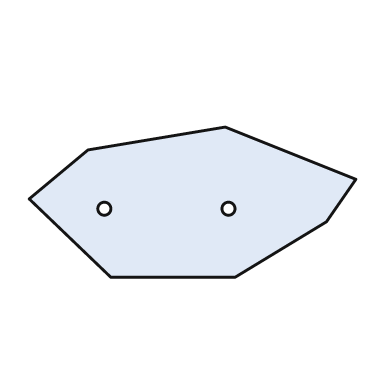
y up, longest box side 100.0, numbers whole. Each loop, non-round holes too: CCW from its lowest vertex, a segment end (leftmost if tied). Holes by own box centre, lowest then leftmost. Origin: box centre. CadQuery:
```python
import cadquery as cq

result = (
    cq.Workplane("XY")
    .moveTo(-25.0, -23.0)
    .lineTo(13.0, -23.0)
    .lineTo(41.0, -6.0)
    .lineTo(50.0, 7.0)
    .lineTo(10.0, 23.0)
    .lineTo(-32.0, 16.0)
    .lineTo(-50.0, 1.0)
    .close()
    .moveTo(-27.0, -2.0)
    .circle(2.0)
    .moveTo(11.0, -2.0)
    .circle(2.0)
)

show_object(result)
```